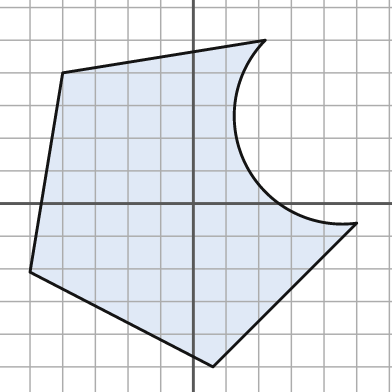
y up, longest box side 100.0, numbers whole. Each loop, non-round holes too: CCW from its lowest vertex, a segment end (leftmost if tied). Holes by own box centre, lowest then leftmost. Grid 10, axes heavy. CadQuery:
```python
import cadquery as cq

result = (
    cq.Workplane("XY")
    .moveTo(6.0, -50.0)
    .lineTo(50.0, -6.0)
    .threePointArc((16.0, 12.0), (22.0, 50.0))
    .lineTo(-40.0, 40.0)
    .lineTo(-50.0, -21.0)
    .close()
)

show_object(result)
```